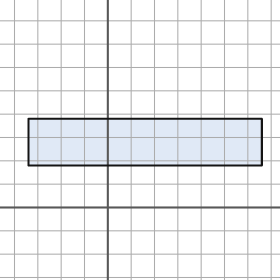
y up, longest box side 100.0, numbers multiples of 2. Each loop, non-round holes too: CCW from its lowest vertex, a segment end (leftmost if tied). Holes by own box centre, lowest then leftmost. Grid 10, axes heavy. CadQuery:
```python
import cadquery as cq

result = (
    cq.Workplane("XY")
    .moveTo(-34.0, 18.0)
    .lineTo(66.0, 18.0)
    .lineTo(66.0, 38.0)
    .lineTo(-34.0, 38.0)
    .close()
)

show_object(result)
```